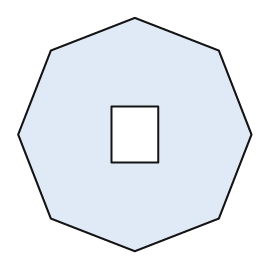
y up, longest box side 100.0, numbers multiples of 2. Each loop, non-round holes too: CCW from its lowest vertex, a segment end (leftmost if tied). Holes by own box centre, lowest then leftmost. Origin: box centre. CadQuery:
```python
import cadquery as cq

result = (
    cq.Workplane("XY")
    .moveTo(0.0, -50.0)
    .lineTo(36.0, -36.0)
    .lineTo(50.0, 0.0)
    .lineTo(36.0, 36.0)
    .lineTo(0.0, 50.0)
    .lineTo(-36.0, 36.0)
    .lineTo(-50.0, 0.0)
    .lineTo(-36.0, -36.0)
    .close()
    .moveTo(-10.0, -12.0)
    .lineTo(10.0, -12.0)
    .lineTo(10.0, 12.0)
    .lineTo(-10.0, 12.0)
    .close()
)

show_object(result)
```